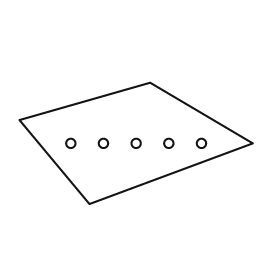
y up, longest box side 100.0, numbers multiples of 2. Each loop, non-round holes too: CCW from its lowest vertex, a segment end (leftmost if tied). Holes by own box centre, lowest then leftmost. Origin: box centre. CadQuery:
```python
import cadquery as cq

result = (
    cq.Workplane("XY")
    .moveTo(-20.0, -26.0)
    .lineTo(50.0, 0.0)
    .lineTo(6.0, 26.0)
    .lineTo(-50.0, 10.0)
    .close()
    .moveTo(-28.0, 0.0)
    .circle(2.0)
    .moveTo(-14.0, 0.0)
    .circle(2.0)
    .moveTo(0.0, 0.0)
    .circle(2.0)
    .moveTo(14.0, 0.0)
    .circle(2.0)
    .moveTo(28.0, 0.0)
    .circle(2.0)
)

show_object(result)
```